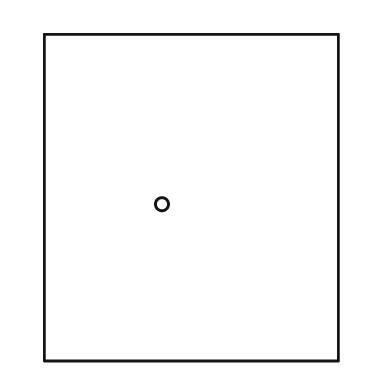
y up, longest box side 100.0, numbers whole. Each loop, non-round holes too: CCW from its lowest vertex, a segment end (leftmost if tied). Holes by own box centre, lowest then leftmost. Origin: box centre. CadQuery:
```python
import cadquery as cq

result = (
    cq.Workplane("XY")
    .moveTo(-45.0, -50.0)
    .lineTo(45.0, -50.0)
    .lineTo(45.0, 50.0)
    .lineTo(-45.0, 50.0)
    .close()
    .moveTo(-9.0, -2.0)
    .circle(2.0)
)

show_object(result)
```